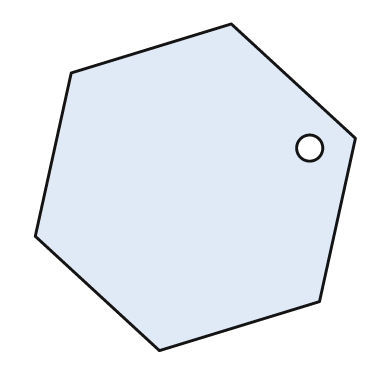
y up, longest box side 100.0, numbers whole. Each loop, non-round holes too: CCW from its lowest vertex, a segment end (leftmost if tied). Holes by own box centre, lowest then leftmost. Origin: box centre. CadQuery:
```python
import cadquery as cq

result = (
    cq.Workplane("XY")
    .moveTo(-11.0, -50.0)
    .lineTo(38.0, -35.0)
    .lineTo(49.0, 15.0)
    .lineTo(11.0, 50.0)
    .lineTo(-38.0, 35.0)
    .lineTo(-49.0, -15.0)
    .close()
    .moveTo(35.0, 12.0)
    .circle(4.0)
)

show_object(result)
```